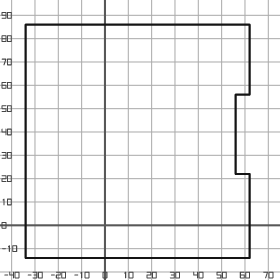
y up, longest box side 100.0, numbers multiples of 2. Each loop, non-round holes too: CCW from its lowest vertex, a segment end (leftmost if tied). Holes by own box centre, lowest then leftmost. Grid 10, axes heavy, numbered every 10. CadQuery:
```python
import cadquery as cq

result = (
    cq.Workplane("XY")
    .moveTo(-34.0, -14.0)
    .lineTo(62.0, -14.0)
    .lineTo(62.0, 22.0)
    .lineTo(56.0, 22.0)
    .lineTo(56.0, 56.0)
    .lineTo(62.0, 56.0)
    .lineTo(62.0, 86.0)
    .lineTo(-34.0, 86.0)
    .close()
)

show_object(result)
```